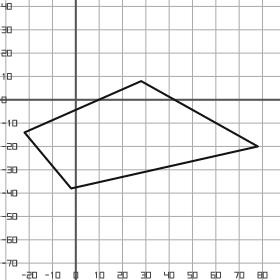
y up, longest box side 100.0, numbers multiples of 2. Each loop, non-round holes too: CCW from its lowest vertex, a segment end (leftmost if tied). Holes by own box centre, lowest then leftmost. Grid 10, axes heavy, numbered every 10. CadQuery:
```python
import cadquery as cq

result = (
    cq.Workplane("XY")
    .moveTo(-2.0, -38.0)
    .lineTo(78.0, -20.0)
    .lineTo(28.0, 8.0)
    .lineTo(-22.0, -14.0)
    .close()
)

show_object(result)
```